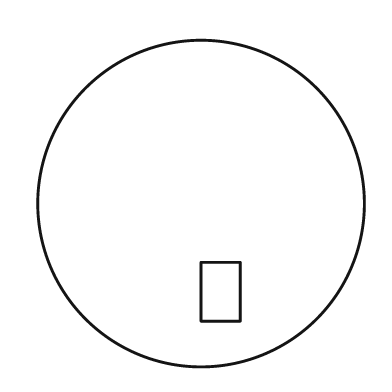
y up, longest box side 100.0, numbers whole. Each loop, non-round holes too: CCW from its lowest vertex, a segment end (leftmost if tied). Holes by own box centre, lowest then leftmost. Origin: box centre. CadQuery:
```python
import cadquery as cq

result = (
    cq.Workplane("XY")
    .moveTo(0.0, 0.0)
    .circle(50.0)
    .moveTo(0.0, -36.0)
    .lineTo(12.0, -36.0)
    .lineTo(12.0, -18.0)
    .lineTo(0.0, -18.0)
    .close()
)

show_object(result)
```